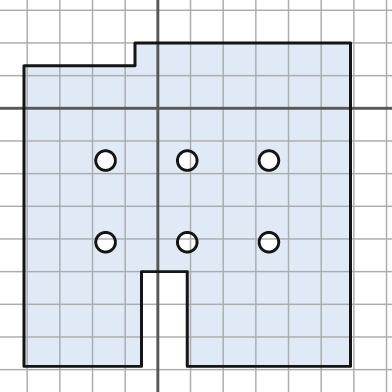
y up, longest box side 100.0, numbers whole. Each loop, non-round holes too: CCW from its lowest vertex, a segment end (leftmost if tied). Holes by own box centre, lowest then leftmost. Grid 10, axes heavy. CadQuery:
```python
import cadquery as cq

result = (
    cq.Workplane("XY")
    .moveTo(-41.0, -79.0)
    .lineTo(-5.0, -79.0)
    .lineTo(-5.0, -50.0)
    .lineTo(9.0, -50.0)
    .lineTo(9.0, -79.0)
    .lineTo(59.0, -79.0)
    .lineTo(59.0, 20.0)
    .lineTo(-7.0, 20.0)
    .lineTo(-7.0, 13.0)
    .lineTo(-41.0, 13.0)
    .close()
    .moveTo(-16.0, -41.0)
    .circle(3.0)
    .moveTo(9.0, -41.0)
    .circle(3.0)
    .moveTo(34.0, -41.0)
    .circle(3.0)
    .moveTo(-16.0, -16.0)
    .circle(3.0)
    .moveTo(9.0, -16.0)
    .circle(3.0)
    .moveTo(34.0, -16.0)
    .circle(3.0)
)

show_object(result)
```